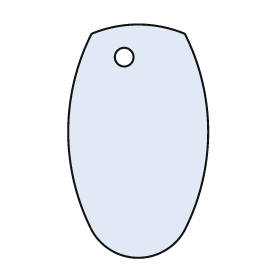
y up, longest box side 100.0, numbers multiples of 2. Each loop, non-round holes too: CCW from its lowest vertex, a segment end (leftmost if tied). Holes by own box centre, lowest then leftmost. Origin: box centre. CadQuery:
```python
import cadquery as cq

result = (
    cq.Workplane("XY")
    .moveTo(-20.0, -38.0)
    .threePointArc((0.0, -50.0), (20.0, -38.0))
    .threePointArc((30.0, 4.0), (20.0, 46.0))
    .threePointArc((0.0, 50.0), (-20.0, 46.0))
    .threePointArc((-30.0, 4.0), (-20.0, -38.0))
    .close()
    .moveTo(-6.0, 36.0)
    .circle(4.0)
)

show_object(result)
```